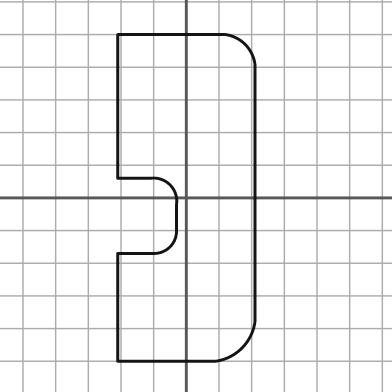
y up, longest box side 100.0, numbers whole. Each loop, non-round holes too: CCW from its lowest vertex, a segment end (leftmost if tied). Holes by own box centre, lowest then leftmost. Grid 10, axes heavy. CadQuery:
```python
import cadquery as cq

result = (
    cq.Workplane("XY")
    .moveTo(-21.0, -50.0)
    .lineTo(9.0, -50.0)
    .threePointArc((17.0, -46.0), (21.0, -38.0))
    .lineTo(21.0, 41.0)
    .threePointArc((18.0, 47.0), (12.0, 50.0))
    .lineTo(-21.0, 50.0)
    .lineTo(-21.0, 6.0)
    .lineTo(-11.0, 6.0)
    .threePointArc((-5.0, 4.0), (-3.0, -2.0))
    .lineTo(-3.0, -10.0)
    .threePointArc((-5.0, -15.0), (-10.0, -17.0))
    .lineTo(-21.0, -17.0)
    .close()
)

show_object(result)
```